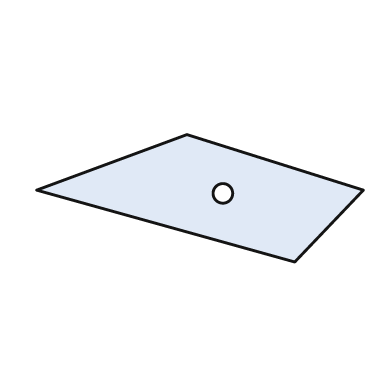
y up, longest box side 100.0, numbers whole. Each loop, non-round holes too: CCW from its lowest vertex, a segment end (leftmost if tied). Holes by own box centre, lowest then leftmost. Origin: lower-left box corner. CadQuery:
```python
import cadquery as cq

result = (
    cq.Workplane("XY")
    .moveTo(79.0, 0.0)
    .lineTo(100.0, 22.0)
    .lineTo(46.0, 39.0)
    .lineTo(0.0, 22.0)
    .close()
    .moveTo(57.0, 21.0)
    .circle(3.0)
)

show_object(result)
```